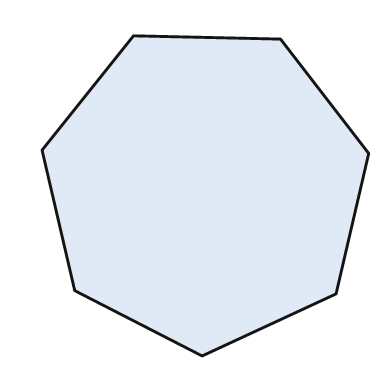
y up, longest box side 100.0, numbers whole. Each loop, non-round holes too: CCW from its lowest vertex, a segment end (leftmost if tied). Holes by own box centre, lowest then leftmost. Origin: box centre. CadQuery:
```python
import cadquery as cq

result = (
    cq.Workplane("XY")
    .moveTo(-1.0, -49.0)
    .lineTo(40.0, -30.0)
    .lineTo(50.0, 13.0)
    .lineTo(23.0, 48.0)
    .lineTo(-22.0, 49.0)
    .lineTo(-50.0, 14.0)
    .lineTo(-40.0, -29.0)
    .close()
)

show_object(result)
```